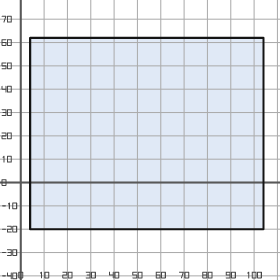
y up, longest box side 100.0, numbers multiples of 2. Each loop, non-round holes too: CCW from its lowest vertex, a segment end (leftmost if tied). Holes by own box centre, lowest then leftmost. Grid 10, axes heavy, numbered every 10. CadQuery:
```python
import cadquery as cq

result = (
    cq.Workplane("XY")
    .moveTo(4.0, -20.0)
    .lineTo(104.0, -20.0)
    .lineTo(104.0, 62.0)
    .lineTo(4.0, 62.0)
    .close()
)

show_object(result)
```